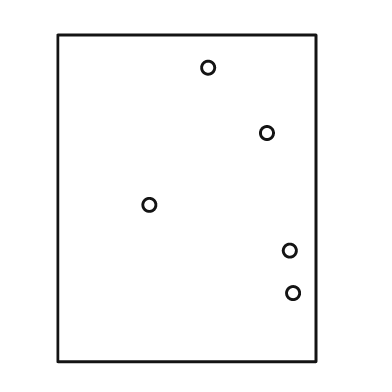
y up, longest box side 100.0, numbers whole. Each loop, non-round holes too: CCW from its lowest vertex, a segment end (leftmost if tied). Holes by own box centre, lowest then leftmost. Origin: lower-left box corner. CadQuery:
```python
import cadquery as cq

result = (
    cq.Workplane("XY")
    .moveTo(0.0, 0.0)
    .lineTo(79.0, 0.0)
    .lineTo(79.0, 100.0)
    .lineTo(0.0, 100.0)
    .close()
    .moveTo(72.0, 21.0)
    .circle(2.0)
    .moveTo(71.0, 34.0)
    .circle(2.0)
    .moveTo(28.0, 48.0)
    .circle(2.0)
    .moveTo(64.0, 70.0)
    .circle(2.0)
    .moveTo(46.0, 90.0)
    .circle(2.0)
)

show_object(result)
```